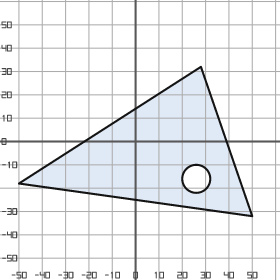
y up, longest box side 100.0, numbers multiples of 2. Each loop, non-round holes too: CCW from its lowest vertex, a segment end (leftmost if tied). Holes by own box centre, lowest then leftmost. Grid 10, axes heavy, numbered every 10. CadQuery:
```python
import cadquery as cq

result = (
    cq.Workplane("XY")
    .moveTo(50.0, -32.0)
    .lineTo(28.0, 32.0)
    .lineTo(-50.0, -18.0)
    .close()
    .moveTo(26.0, -16.0)
    .circle(6.0)
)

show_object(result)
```